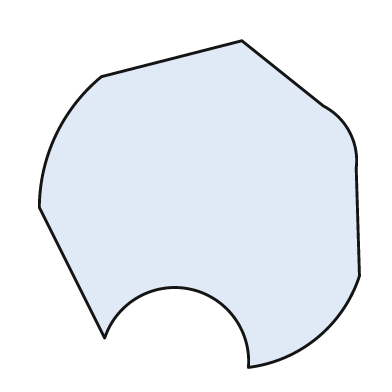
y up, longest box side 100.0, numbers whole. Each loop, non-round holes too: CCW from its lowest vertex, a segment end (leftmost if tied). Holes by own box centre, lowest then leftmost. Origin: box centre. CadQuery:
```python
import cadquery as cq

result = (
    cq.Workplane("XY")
    .moveTo(15.0, -50.0)
    .threePointArc((36.0, -41.0), (49.0, -22.0))
    .lineTo(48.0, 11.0)
    .threePointArc((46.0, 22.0), (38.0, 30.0))
    .lineTo(13.0, 50.0)
    .lineTo(-30.0, 39.0)
    .threePointArc((-44.0, 21.0), (-49.0, -1.0))
    .lineTo(-29.0, -41.0)
    .threePointArc((-3.0, -26.0), (15.0, -50.0))
    .close()
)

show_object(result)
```